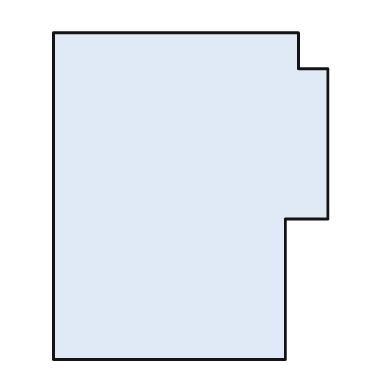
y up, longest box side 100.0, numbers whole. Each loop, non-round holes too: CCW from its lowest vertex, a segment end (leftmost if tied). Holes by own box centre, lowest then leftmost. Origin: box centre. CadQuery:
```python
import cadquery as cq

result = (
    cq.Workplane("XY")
    .moveTo(-42.0, -50.0)
    .lineTo(29.0, -50.0)
    .lineTo(29.0, -7.0)
    .lineTo(42.0, -7.0)
    .lineTo(42.0, 39.0)
    .lineTo(33.0, 39.0)
    .lineTo(33.0, 50.0)
    .lineTo(-42.0, 50.0)
    .close()
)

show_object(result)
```